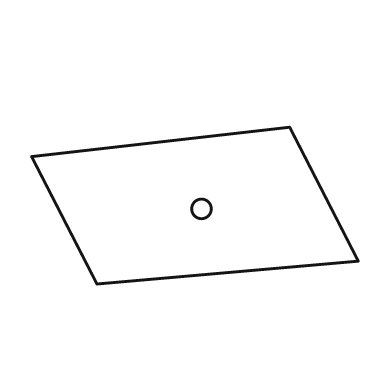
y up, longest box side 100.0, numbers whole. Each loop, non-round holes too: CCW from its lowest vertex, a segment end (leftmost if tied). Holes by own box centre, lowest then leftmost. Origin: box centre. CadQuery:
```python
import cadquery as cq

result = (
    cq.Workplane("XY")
    .moveTo(-30.0, -24.0)
    .lineTo(50.0, -17.0)
    .lineTo(29.0, 24.0)
    .lineTo(-50.0, 15.0)
    .close()
    .moveTo(2.0, -1.0)
    .circle(3.0)
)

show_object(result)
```